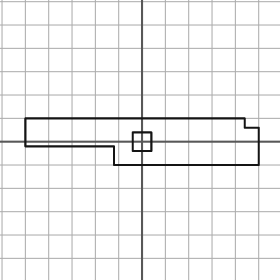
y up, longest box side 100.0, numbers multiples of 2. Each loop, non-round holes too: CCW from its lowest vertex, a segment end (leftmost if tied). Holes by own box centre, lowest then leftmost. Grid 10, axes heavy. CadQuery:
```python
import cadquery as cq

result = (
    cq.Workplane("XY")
    .moveTo(-12.0, -10.0)
    .lineTo(50.0, -10.0)
    .lineTo(50.0, 6.0)
    .lineTo(44.0, 6.0)
    .lineTo(44.0, 10.0)
    .lineTo(-50.0, 10.0)
    .lineTo(-50.0, -2.0)
    .lineTo(-12.0, -2.0)
    .close()
    .moveTo(-4.0, -4.0)
    .lineTo(4.0, -4.0)
    .lineTo(4.0, 4.0)
    .lineTo(-4.0, 4.0)
    .close()
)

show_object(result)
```